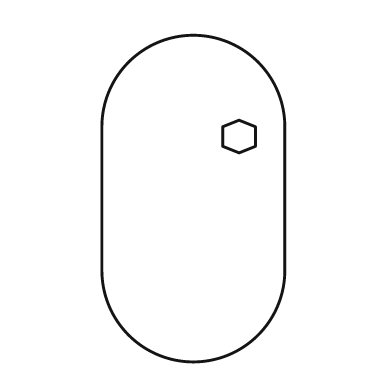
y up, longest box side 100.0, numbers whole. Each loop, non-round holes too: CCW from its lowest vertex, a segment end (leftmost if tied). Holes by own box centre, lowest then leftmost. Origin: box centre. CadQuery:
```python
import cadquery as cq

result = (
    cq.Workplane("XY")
    .moveTo(-28.0, -22.0)
    .threePointArc((0.0, -50.0), (28.0, -22.0))
    .lineTo(28.0, 22.0)
    .threePointArc((0.0, 50.0), (-28.0, 22.0))
    .close()
    .moveTo(14.0, 14.0)
    .lineTo(19.0, 16.0)
    .lineTo(19.0, 22.0)
    .lineTo(14.0, 24.0)
    .lineTo(9.0, 22.0)
    .lineTo(9.0, 16.0)
    .close()
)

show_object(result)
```